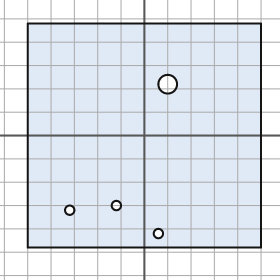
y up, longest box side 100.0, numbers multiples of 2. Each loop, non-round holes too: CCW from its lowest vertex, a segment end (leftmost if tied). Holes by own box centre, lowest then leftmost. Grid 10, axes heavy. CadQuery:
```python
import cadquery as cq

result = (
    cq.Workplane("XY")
    .moveTo(-50.0, -48.0)
    .lineTo(50.0, -48.0)
    .lineTo(50.0, 48.0)
    .lineTo(-50.0, 48.0)
    .close()
    .moveTo(6.0, -42.0)
    .circle(2.0)
    .moveTo(-32.0, -32.0)
    .circle(2.0)
    .moveTo(-12.0, -30.0)
    .circle(2.0)
    .moveTo(10.0, 22.0)
    .circle(4.0)
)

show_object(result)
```